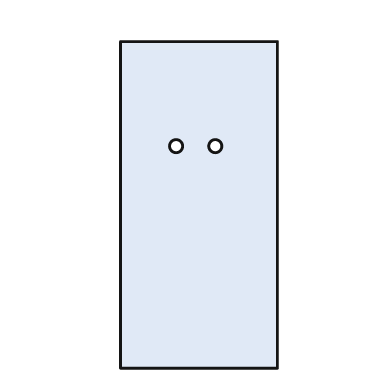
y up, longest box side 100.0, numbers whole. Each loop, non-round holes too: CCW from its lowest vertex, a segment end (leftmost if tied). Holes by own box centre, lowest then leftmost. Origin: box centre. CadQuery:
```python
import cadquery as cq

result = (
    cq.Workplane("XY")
    .moveTo(-24.0, -50.0)
    .lineTo(24.0, -50.0)
    .lineTo(24.0, 50.0)
    .lineTo(-24.0, 50.0)
    .close()
    .moveTo(-7.0, 18.0)
    .circle(2.0)
    .moveTo(5.0, 18.0)
    .circle(2.0)
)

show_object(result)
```